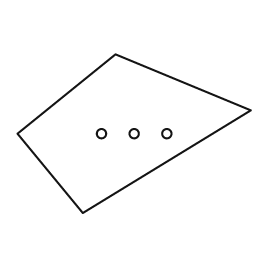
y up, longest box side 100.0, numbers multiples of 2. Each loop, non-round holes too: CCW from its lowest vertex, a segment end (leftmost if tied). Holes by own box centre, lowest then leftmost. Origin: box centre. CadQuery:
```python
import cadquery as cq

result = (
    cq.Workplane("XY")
    .moveTo(-22.0, -34.0)
    .lineTo(50.0, 10.0)
    .lineTo(-8.0, 34.0)
    .lineTo(-50.0, 0.0)
    .close()
    .moveTo(-14.0, 0.0)
    .circle(2.0)
    .moveTo(0.0, 0.0)
    .circle(2.0)
    .moveTo(14.0, 0.0)
    .circle(2.0)
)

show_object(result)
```